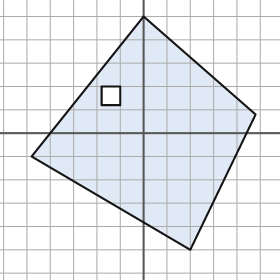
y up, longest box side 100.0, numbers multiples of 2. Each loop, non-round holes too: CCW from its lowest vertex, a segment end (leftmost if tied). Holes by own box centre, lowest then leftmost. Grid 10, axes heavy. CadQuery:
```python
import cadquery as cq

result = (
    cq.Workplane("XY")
    .moveTo(20.0, -50.0)
    .lineTo(48.0, 8.0)
    .lineTo(0.0, 50.0)
    .lineTo(-48.0, -10.0)
    .close()
    .moveTo(-18.0, 12.0)
    .lineTo(-10.0, 12.0)
    .lineTo(-10.0, 20.0)
    .lineTo(-18.0, 20.0)
    .close()
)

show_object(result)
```